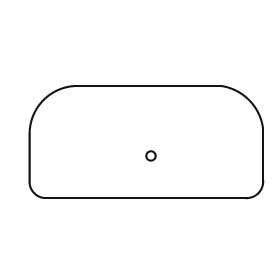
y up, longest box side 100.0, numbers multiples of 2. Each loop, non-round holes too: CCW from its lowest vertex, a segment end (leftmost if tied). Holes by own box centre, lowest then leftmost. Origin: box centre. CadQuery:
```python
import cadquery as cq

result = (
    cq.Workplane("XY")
    .moveTo(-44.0, -24.0)
    .lineTo(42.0, -24.0)
    .threePointArc((48.0, -22.0), (50.0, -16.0))
    .lineTo(50.0, 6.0)
    .threePointArc((44.0, 18.0), (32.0, 24.0))
    .lineTo(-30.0, 24.0)
    .threePointArc((-44.0, 18.0), (-50.0, 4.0))
    .lineTo(-50.0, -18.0)
    .threePointArc((-48.0, -22.0), (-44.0, -24.0))
    .close()
    .moveTo(2.0, -6.0)
    .circle(2.0)
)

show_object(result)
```